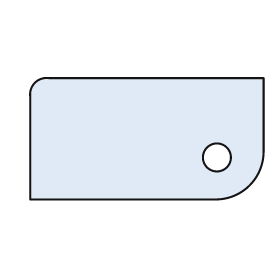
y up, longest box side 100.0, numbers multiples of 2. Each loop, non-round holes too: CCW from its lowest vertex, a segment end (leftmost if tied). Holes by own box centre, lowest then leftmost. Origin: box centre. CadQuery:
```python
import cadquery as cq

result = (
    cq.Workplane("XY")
    .moveTo(-50.0, -26.0)
    .lineTo(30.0, -26.0)
    .threePointArc((44.0, -20.0), (50.0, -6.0))
    .lineTo(50.0, 26.0)
    .lineTo(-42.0, 26.0)
    .threePointArc((-48.0, 24.0), (-50.0, 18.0))
    .close()
    .moveTo(30.0, -8.0)
    .circle(6.0)
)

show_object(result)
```